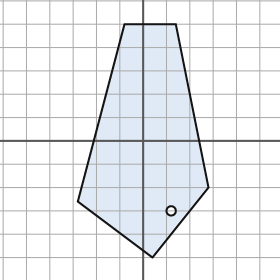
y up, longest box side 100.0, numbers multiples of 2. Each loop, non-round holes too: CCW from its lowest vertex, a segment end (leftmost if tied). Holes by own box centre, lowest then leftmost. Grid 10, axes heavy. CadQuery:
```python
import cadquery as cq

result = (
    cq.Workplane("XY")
    .moveTo(4.0, -50.0)
    .lineTo(28.0, -20.0)
    .lineTo(14.0, 50.0)
    .lineTo(-8.0, 50.0)
    .lineTo(-28.0, -26.0)
    .close()
    .moveTo(12.0, -30.0)
    .circle(2.0)
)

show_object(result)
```